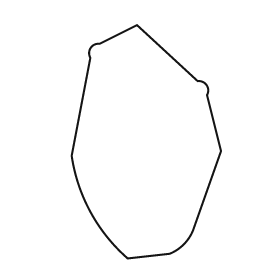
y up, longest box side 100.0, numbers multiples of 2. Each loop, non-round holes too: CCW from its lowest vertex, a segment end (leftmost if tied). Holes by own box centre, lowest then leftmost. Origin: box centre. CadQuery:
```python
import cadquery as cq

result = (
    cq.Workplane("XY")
    .moveTo(-8.0, -50.0)
    .lineTo(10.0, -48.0)
    .threePointArc((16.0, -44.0), (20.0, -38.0))
    .lineTo(32.0, -4.0)
    .lineTo(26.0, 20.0)
    .threePointArc((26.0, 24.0), (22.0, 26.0))
    .lineTo(-4.0, 50.0)
    .lineTo(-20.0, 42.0)
    .threePointArc((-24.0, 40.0), (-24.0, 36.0))
    .lineTo(-32.0, -6.0)
    .threePointArc((-24.0, -30.0), (-8.0, -50.0))
    .close()
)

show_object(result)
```